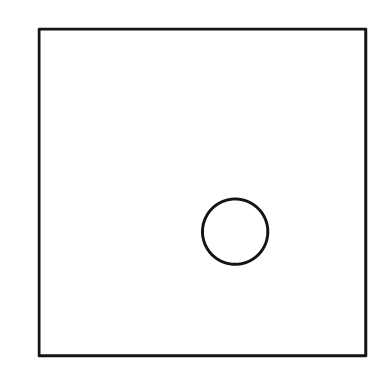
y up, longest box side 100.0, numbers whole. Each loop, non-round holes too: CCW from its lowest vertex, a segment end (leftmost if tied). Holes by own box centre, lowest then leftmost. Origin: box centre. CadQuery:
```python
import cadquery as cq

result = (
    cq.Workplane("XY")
    .moveTo(-50.0, -50.0)
    .lineTo(50.0, -50.0)
    .lineTo(50.0, 50.0)
    .lineTo(-50.0, 50.0)
    .close()
    .moveTo(10.0, -12.0)
    .circle(10.0)
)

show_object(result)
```